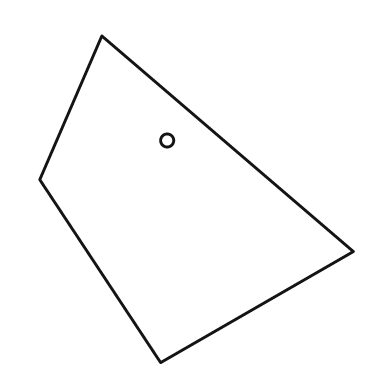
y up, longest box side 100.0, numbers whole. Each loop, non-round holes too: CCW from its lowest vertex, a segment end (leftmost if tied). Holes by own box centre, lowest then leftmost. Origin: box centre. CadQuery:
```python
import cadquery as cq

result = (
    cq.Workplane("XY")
    .moveTo(-11.0, -50.0)
    .lineTo(48.0, -16.0)
    .lineTo(-29.0, 50.0)
    .lineTo(-48.0, 6.0)
    .close()
    .moveTo(-9.0, 18.0)
    .circle(2.0)
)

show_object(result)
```